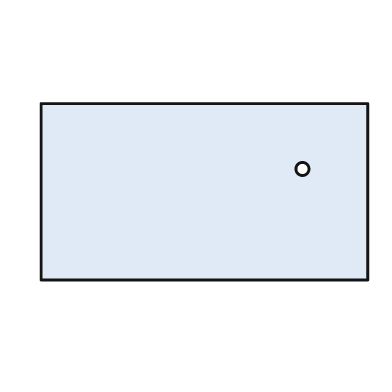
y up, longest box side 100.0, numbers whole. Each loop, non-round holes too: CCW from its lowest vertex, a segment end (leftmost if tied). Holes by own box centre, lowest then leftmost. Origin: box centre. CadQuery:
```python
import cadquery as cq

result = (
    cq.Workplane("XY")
    .moveTo(-50.0, -27.0)
    .lineTo(50.0, -27.0)
    .lineTo(50.0, 27.0)
    .lineTo(-50.0, 27.0)
    .close()
    .moveTo(30.0, 7.0)
    .circle(2.0)
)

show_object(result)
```